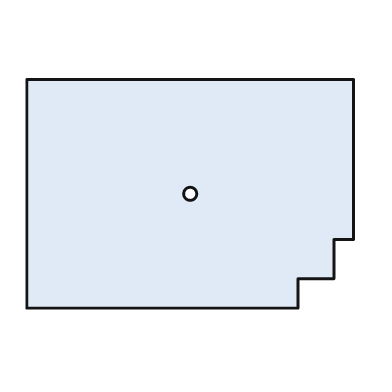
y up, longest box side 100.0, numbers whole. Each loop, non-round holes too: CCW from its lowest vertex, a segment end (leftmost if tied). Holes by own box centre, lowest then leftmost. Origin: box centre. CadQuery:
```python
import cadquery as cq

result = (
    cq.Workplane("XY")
    .moveTo(-50.0, -35.0)
    .lineTo(33.0, -35.0)
    .lineTo(33.0, -26.0)
    .lineTo(44.0, -26.0)
    .lineTo(44.0, -14.0)
    .lineTo(50.0, -14.0)
    .lineTo(50.0, 35.0)
    .lineTo(-50.0, 35.0)
    .close()
    .moveTo(0.0, 0.0)
    .circle(2.0)
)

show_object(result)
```